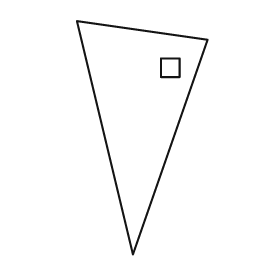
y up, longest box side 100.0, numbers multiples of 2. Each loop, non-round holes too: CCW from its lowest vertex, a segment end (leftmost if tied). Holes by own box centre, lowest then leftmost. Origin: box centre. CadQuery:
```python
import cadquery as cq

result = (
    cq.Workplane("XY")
    .moveTo(-4.0, -50.0)
    .lineTo(28.0, 42.0)
    .lineTo(-28.0, 50.0)
    .close()
    .moveTo(8.0, 26.0)
    .lineTo(16.0, 26.0)
    .lineTo(16.0, 34.0)
    .lineTo(8.0, 34.0)
    .close()
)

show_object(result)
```